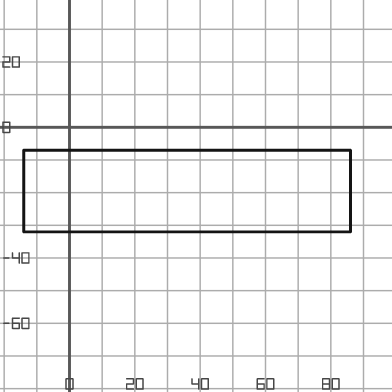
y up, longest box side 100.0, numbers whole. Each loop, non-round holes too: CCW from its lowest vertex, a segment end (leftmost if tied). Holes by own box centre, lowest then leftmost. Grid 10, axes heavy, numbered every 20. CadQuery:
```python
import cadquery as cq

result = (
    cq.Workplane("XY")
    .moveTo(-14.0, -32.0)
    .lineTo(86.0, -32.0)
    .lineTo(86.0, -7.0)
    .lineTo(-14.0, -7.0)
    .close()
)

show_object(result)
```